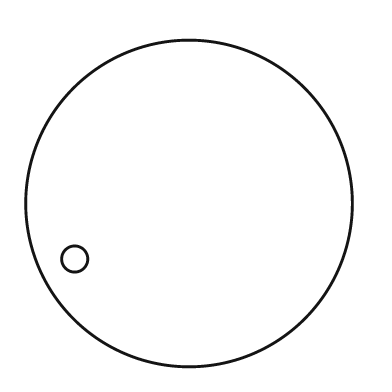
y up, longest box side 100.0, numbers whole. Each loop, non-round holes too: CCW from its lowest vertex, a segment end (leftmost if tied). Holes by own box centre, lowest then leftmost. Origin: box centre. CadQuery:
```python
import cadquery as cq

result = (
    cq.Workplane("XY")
    .moveTo(0.0, 0.0)
    .circle(50.0)
    .moveTo(-35.0, -17.0)
    .circle(4.0)
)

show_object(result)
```